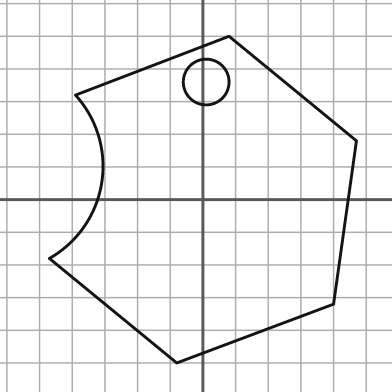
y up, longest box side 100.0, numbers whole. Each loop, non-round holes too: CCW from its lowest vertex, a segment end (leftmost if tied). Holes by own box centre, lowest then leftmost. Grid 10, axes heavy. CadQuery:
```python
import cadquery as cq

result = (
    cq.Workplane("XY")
    .moveTo(-8.0, -50.0)
    .lineTo(40.0, -32.0)
    .lineTo(47.0, 18.0)
    .lineTo(8.0, 50.0)
    .lineTo(-39.0, 32.0)
    .threePointArc((-31.0, 5.0), (-47.0, -18.0))
    .close()
    .moveTo(1.0, 36.0)
    .circle(7.0)
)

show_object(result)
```